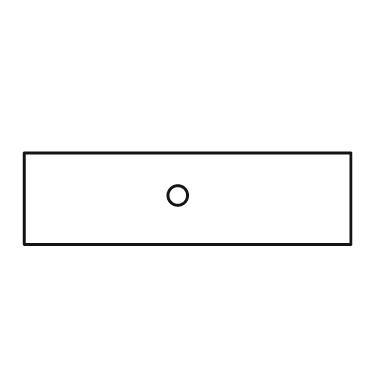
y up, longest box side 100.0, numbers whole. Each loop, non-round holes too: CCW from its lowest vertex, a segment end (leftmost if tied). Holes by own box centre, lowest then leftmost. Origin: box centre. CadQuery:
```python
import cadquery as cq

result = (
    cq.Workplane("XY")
    .moveTo(-50.0, -14.0)
    .lineTo(50.0, -14.0)
    .lineTo(50.0, 14.0)
    .lineTo(-50.0, 14.0)
    .close()
    .moveTo(-3.0, 1.0)
    .circle(3.0)
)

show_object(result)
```